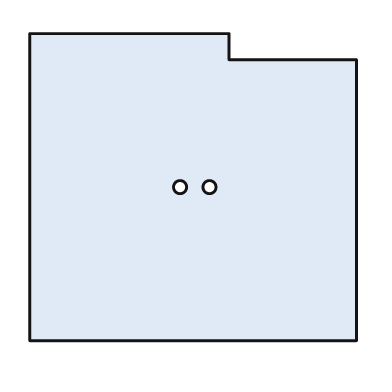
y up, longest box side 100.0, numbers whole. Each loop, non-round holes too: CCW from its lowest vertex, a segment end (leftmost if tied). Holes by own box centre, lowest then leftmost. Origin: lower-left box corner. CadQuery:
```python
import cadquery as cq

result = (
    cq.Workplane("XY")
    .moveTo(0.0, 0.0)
    .lineTo(100.0, 0.0)
    .lineTo(100.0, 86.0)
    .lineTo(61.0, 86.0)
    .lineTo(61.0, 94.0)
    .lineTo(0.0, 94.0)
    .close()
    .moveTo(46.0, 47.0)
    .circle(2.0)
    .moveTo(55.0, 47.0)
    .circle(2.0)
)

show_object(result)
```